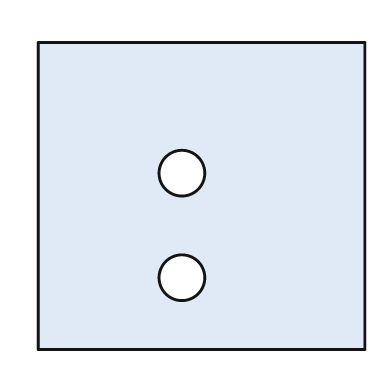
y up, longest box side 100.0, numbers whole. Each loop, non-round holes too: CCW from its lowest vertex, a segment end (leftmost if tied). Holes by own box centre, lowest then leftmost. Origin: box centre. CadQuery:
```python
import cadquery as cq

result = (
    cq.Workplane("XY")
    .moveTo(-50.0, -47.0)
    .lineTo(50.0, -47.0)
    .lineTo(50.0, 47.0)
    .lineTo(-50.0, 47.0)
    .close()
    .moveTo(-6.0, -25.0)
    .circle(7.0)
    .moveTo(-6.0, 7.0)
    .circle(7.0)
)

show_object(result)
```